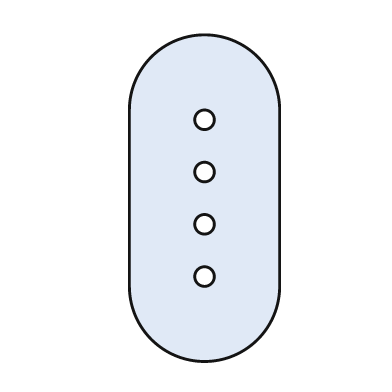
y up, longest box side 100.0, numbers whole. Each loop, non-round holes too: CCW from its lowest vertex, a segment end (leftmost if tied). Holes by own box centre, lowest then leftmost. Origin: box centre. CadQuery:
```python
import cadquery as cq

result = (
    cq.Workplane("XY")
    .moveTo(-23.0, -27.0)
    .threePointArc((0.0, -50.0), (23.0, -27.0))
    .lineTo(23.0, 27.0)
    .threePointArc((0.0, 50.0), (-23.0, 27.0))
    .close()
    .moveTo(0.0, -24.0)
    .circle(3.0)
    .moveTo(0.0, -8.0)
    .circle(3.0)
    .moveTo(0.0, 8.0)
    .circle(3.0)
    .moveTo(0.0, 24.0)
    .circle(3.0)
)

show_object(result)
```